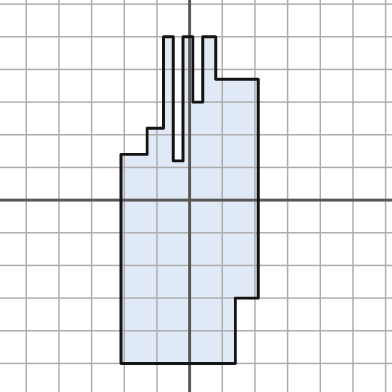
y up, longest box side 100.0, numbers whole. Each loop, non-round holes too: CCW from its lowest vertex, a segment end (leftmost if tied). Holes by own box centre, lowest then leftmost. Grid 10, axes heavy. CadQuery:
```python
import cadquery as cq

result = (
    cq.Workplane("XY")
    .moveTo(-21.0, -50.0)
    .lineTo(14.0, -50.0)
    .lineTo(14.0, -30.0)
    .lineTo(21.0, -30.0)
    .lineTo(21.0, 37.0)
    .lineTo(8.0, 37.0)
    .lineTo(8.0, 50.0)
    .lineTo(4.0, 50.0)
    .lineTo(4.0, 30.0)
    .lineTo(1.0, 30.0)
    .lineTo(1.0, 50.0)
    .lineTo(-2.0, 50.0)
    .lineTo(-2.0, 12.0)
    .lineTo(-5.0, 12.0)
    .lineTo(-5.0, 50.0)
    .lineTo(-8.0, 50.0)
    .lineTo(-8.0, 22.0)
    .lineTo(-13.0, 22.0)
    .lineTo(-13.0, 14.0)
    .lineTo(-21.0, 14.0)
    .close()
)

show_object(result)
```